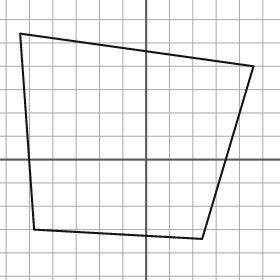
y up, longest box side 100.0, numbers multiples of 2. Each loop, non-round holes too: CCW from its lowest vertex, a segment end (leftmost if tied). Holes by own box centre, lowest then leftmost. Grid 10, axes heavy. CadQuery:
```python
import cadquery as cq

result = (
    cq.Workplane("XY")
    .moveTo(24.0, -34.0)
    .lineTo(46.0, 40.0)
    .lineTo(-54.0, 54.0)
    .lineTo(-48.0, -30.0)
    .close()
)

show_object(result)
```